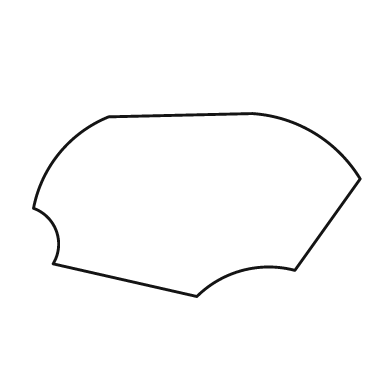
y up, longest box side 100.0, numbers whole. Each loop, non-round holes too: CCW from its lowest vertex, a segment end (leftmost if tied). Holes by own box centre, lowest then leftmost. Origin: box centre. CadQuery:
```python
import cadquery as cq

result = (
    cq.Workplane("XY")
    .moveTo(0.0, -28.0)
    .threePointArc((14.0, -20.0), (30.0, -20.0))
    .lineTo(50.0, 8.0)
    .threePointArc((36.0, 22.0), (17.0, 28.0))
    .lineTo(-27.0, 27.0)
    .threePointArc((-42.0, 16.0), (-50.0, -1.0))
    .threePointArc((-43.0, -8.0), (-44.0, -18.0))
    .close()
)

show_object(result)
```